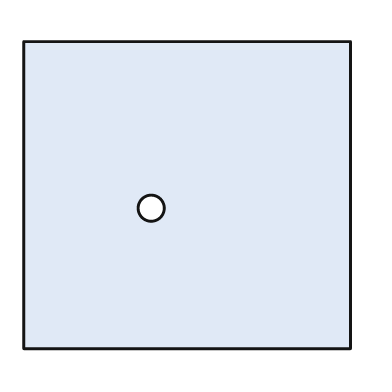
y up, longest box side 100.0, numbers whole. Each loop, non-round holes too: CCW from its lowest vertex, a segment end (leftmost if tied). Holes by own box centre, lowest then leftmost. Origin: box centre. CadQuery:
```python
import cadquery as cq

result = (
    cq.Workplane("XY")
    .moveTo(-50.0, -47.0)
    .lineTo(50.0, -47.0)
    .lineTo(50.0, 47.0)
    .lineTo(-50.0, 47.0)
    .close()
    .moveTo(-11.0, -4.0)
    .circle(4.0)
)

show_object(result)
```